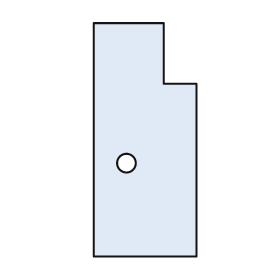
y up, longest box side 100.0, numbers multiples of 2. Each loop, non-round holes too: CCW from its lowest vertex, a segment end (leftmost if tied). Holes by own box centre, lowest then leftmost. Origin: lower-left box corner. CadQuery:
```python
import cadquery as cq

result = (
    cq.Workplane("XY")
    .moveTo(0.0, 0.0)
    .lineTo(44.0, 0.0)
    .lineTo(44.0, 74.0)
    .lineTo(30.0, 74.0)
    .lineTo(30.0, 100.0)
    .lineTo(0.0, 100.0)
    .close()
    .moveTo(14.0, 40.0)
    .circle(4.0)
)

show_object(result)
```